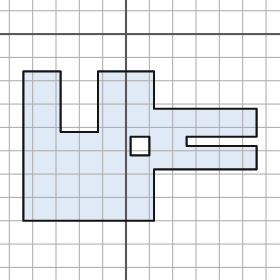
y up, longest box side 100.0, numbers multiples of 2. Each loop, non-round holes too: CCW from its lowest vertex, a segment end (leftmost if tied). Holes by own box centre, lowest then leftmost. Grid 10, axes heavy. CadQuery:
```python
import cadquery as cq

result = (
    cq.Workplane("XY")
    .moveTo(-44.0, -80.0)
    .lineTo(12.0, -80.0)
    .lineTo(12.0, -58.0)
    .lineTo(56.0, -58.0)
    .lineTo(56.0, -48.0)
    .lineTo(26.0, -48.0)
    .lineTo(26.0, -44.0)
    .lineTo(56.0, -44.0)
    .lineTo(56.0, -32.0)
    .lineTo(12.0, -32.0)
    .lineTo(12.0, -16.0)
    .lineTo(-12.0, -16.0)
    .lineTo(-12.0, -42.0)
    .lineTo(-28.0, -42.0)
    .lineTo(-28.0, -16.0)
    .lineTo(-44.0, -16.0)
    .close()
    .moveTo(2.0, -52.0)
    .lineTo(10.0, -52.0)
    .lineTo(10.0, -44.0)
    .lineTo(2.0, -44.0)
    .close()
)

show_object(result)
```